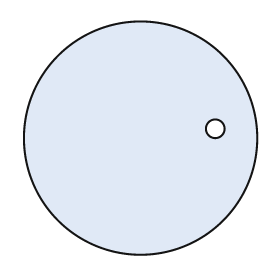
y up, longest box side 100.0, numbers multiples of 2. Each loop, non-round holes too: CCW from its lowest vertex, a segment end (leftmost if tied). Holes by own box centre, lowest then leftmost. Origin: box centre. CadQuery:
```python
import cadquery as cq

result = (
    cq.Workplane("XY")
    .moveTo(0.0, 0.0)
    .circle(50.0)
    .moveTo(32.0, 4.0)
    .circle(4.0)
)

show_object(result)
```